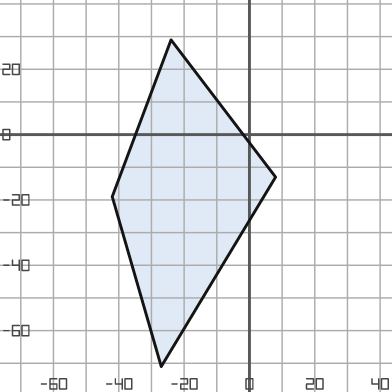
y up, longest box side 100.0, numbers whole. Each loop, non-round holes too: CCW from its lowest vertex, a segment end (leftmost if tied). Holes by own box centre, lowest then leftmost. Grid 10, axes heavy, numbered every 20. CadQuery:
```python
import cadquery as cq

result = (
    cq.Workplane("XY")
    .moveTo(-27.0, -71.0)
    .lineTo(8.0, -13.0)
    .lineTo(-24.0, 29.0)
    .lineTo(-42.0, -19.0)
    .close()
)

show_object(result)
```